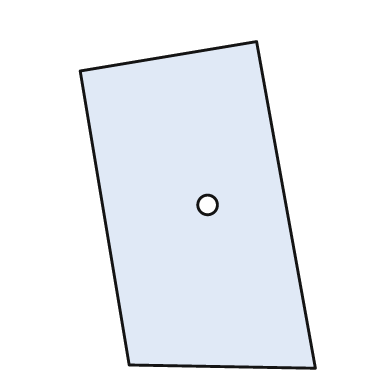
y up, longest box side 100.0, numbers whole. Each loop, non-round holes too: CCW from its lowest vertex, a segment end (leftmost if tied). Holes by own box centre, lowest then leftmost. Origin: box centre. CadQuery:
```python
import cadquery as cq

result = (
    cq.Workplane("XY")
    .moveTo(36.0, -50.0)
    .lineTo(18.0, 50.0)
    .lineTo(-36.0, 41.0)
    .lineTo(-21.0, -49.0)
    .close()
    .moveTo(3.0, 0.0)
    .circle(3.0)
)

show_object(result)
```